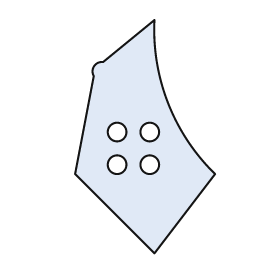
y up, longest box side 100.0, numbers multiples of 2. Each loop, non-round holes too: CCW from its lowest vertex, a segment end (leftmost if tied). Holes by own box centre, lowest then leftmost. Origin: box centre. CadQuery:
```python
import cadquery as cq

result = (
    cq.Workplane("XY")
    .moveTo(4.0, -50.0)
    .lineTo(30.0, -16.0)
    .threePointArc((10.0, 14.0), (4.0, 50.0))
    .lineTo(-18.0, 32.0)
    .threePointArc((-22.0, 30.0), (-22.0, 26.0))
    .lineTo(-30.0, -16.0)
    .close()
    .moveTo(-12.0, -12.0)
    .circle(4.0)
    .moveTo(2.0, -12.0)
    .circle(4.0)
    .moveTo(-12.0, 2.0)
    .circle(4.0)
    .moveTo(2.0, 2.0)
    .circle(4.0)
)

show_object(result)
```